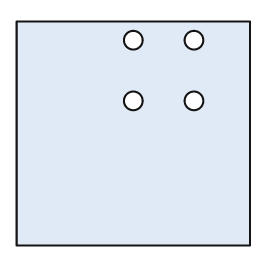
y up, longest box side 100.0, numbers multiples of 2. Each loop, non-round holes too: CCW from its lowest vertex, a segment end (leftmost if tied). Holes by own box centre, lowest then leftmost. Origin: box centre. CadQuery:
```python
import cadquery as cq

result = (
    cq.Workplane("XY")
    .moveTo(-50.0, -48.0)
    .lineTo(50.0, -48.0)
    .lineTo(50.0, 48.0)
    .lineTo(-50.0, 48.0)
    .close()
    .moveTo(0.0, 14.0)
    .circle(4.0)
    .moveTo(26.0, 14.0)
    .circle(4.0)
    .moveTo(0.0, 40.0)
    .circle(4.0)
    .moveTo(26.0, 40.0)
    .circle(4.0)
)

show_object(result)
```